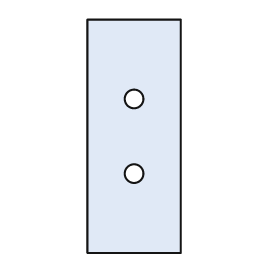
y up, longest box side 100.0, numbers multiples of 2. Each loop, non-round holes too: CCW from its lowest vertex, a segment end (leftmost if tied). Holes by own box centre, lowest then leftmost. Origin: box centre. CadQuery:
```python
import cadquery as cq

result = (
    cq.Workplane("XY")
    .moveTo(-20.0, -50.0)
    .lineTo(20.0, -50.0)
    .lineTo(20.0, 50.0)
    .lineTo(-20.0, 50.0)
    .close()
    .moveTo(0.0, -16.0)
    .circle(4.0)
    .moveTo(0.0, 16.0)
    .circle(4.0)
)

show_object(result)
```